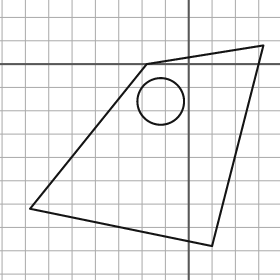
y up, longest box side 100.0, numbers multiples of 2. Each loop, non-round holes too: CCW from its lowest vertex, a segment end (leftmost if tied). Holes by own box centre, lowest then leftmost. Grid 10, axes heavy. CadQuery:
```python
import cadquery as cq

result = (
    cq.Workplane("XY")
    .moveTo(10.0, -78.0)
    .lineTo(32.0, 8.0)
    .lineTo(-18.0, 0.0)
    .lineTo(-68.0, -62.0)
    .close()
    .moveTo(-12.0, -16.0)
    .circle(10.0)
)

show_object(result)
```